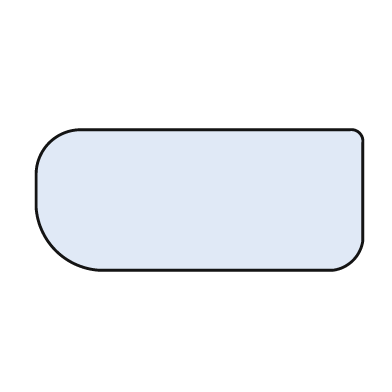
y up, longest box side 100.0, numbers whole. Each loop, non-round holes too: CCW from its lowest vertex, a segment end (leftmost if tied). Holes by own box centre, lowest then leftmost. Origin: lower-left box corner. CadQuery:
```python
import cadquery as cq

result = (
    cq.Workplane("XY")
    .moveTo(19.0, 0.0)
    .lineTo(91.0, 0.0)
    .threePointArc((97.0, 3.0), (100.0, 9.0))
    .lineTo(100.0, 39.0)
    .threePointArc((99.0, 42.0), (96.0, 43.0))
    .lineTo(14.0, 43.0)
    .threePointArc((4.0, 39.0), (0.0, 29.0))
    .lineTo(0.0, 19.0)
    .threePointArc((6.0, 6.0), (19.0, 0.0))
    .close()
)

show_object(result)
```